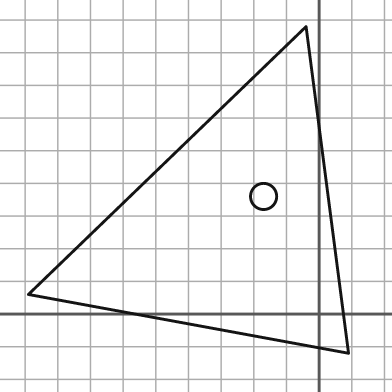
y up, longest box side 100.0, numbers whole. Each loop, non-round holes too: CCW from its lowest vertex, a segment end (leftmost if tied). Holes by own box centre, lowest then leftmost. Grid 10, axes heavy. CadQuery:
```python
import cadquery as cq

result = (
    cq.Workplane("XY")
    .moveTo(9.0, -12.0)
    .lineTo(-4.0, 88.0)
    .lineTo(-89.0, 6.0)
    .close()
    .moveTo(-17.0, 36.0)
    .circle(4.0)
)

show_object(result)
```